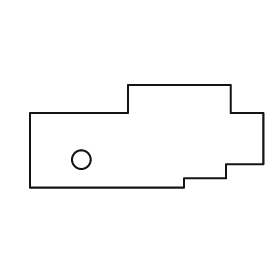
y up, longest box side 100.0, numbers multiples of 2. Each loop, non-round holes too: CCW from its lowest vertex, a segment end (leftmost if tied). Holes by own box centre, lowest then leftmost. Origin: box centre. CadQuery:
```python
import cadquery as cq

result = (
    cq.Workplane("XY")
    .moveTo(-50.0, -22.0)
    .lineTo(16.0, -22.0)
    .lineTo(16.0, -18.0)
    .lineTo(34.0, -18.0)
    .lineTo(34.0, -12.0)
    .lineTo(50.0, -12.0)
    .lineTo(50.0, 10.0)
    .lineTo(36.0, 10.0)
    .lineTo(36.0, 22.0)
    .lineTo(-8.0, 22.0)
    .lineTo(-8.0, 10.0)
    .lineTo(-50.0, 10.0)
    .close()
    .moveTo(-28.0, -10.0)
    .circle(4.0)
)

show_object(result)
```